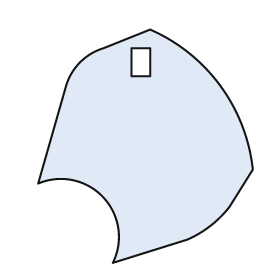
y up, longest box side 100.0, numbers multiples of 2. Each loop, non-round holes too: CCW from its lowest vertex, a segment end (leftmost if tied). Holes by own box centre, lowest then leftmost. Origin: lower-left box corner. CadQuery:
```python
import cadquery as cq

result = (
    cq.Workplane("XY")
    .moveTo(32.0, 0.0)
    .lineTo(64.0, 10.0)
    .threePointArc((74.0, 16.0), (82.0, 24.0))
    .lineTo(92.0, 40.0)
    .threePointArc((78.0, 76.0), (48.0, 100.0))
    .lineTo(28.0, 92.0)
    .threePointArc((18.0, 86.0), (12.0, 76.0))
    .lineTo(0.0, 34.0)
    .threePointArc((28.0, 28.0), (32.0, 0.0))
    .close()
    .moveTo(40.0, 80.0)
    .lineTo(48.0, 80.0)
    .lineTo(48.0, 92.0)
    .lineTo(40.0, 92.0)
    .close()
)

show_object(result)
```